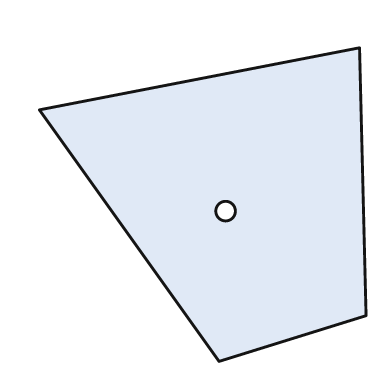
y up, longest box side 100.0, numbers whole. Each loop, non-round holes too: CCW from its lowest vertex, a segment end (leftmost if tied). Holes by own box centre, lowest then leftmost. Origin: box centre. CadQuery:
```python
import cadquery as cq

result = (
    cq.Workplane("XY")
    .moveTo(5.0, -48.0)
    .lineTo(50.0, -34.0)
    .lineTo(48.0, 48.0)
    .lineTo(-50.0, 29.0)
    .close()
    .moveTo(7.0, -2.0)
    .circle(3.0)
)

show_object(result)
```